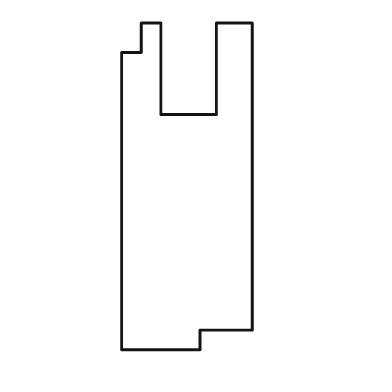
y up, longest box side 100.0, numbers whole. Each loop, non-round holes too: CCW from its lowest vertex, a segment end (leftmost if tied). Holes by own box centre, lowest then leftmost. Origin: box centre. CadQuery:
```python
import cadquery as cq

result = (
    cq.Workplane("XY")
    .moveTo(-20.0, -50.0)
    .lineTo(4.0, -50.0)
    .lineTo(4.0, -44.0)
    .lineTo(20.0, -44.0)
    .lineTo(20.0, 50.0)
    .lineTo(9.0, 50.0)
    .lineTo(9.0, 22.0)
    .lineTo(-8.0, 22.0)
    .lineTo(-8.0, 50.0)
    .lineTo(-14.0, 50.0)
    .lineTo(-14.0, 41.0)
    .lineTo(-20.0, 41.0)
    .close()
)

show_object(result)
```